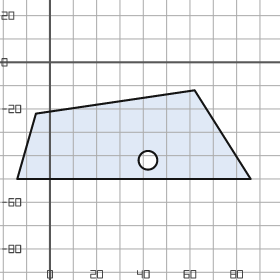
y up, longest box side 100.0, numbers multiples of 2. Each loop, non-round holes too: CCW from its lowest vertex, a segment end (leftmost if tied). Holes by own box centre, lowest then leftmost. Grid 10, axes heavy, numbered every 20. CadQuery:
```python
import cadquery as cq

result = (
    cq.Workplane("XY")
    .moveTo(-14.0, -50.0)
    .lineTo(86.0, -50.0)
    .lineTo(62.0, -12.0)
    .lineTo(-6.0, -22.0)
    .close()
    .moveTo(42.0, -42.0)
    .circle(4.0)
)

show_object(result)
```